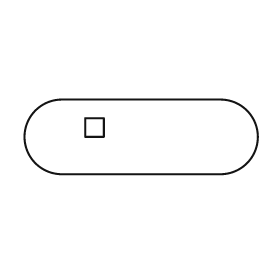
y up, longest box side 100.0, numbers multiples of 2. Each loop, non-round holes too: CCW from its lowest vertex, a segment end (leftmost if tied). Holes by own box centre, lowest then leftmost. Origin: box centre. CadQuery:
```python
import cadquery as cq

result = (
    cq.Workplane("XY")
    .moveTo(-34.0, -16.0)
    .lineTo(34.0, -16.0)
    .threePointArc((50.0, 0.0), (34.0, 16.0))
    .lineTo(-34.0, 16.0)
    .threePointArc((-50.0, 0.0), (-34.0, -16.0))
    .close()
    .moveTo(-24.0, 0.0)
    .lineTo(-16.0, 0.0)
    .lineTo(-16.0, 8.0)
    .lineTo(-24.0, 8.0)
    .close()
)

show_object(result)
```